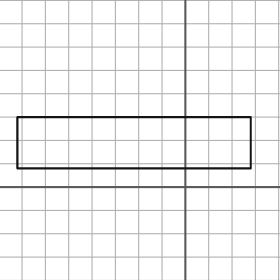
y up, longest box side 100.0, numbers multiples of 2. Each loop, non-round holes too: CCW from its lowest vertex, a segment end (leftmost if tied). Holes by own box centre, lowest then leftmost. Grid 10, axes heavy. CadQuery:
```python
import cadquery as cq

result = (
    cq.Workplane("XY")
    .moveTo(-72.0, 8.0)
    .lineTo(28.0, 8.0)
    .lineTo(28.0, 30.0)
    .lineTo(-72.0, 30.0)
    .close()
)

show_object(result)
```